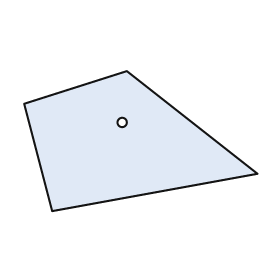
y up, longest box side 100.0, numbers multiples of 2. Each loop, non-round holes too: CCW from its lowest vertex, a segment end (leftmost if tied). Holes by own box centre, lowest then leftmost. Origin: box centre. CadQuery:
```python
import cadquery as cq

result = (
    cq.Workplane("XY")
    .moveTo(-38.0, -30.0)
    .lineTo(50.0, -14.0)
    .lineTo(-6.0, 30.0)
    .lineTo(-50.0, 16.0)
    .close()
    .moveTo(-8.0, 8.0)
    .circle(2.0)
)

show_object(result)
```